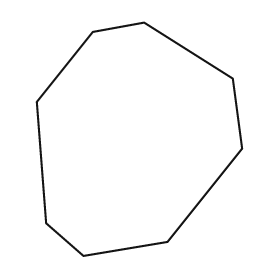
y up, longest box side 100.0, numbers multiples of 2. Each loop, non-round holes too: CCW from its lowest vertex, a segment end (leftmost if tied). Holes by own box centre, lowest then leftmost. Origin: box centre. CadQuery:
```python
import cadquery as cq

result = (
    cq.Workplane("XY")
    .moveTo(-24.0, -50.0)
    .lineTo(12.0, -44.0)
    .lineTo(44.0, -4.0)
    .lineTo(40.0, 26.0)
    .lineTo(2.0, 50.0)
    .lineTo(-20.0, 46.0)
    .lineTo(-44.0, 16.0)
    .lineTo(-40.0, -36.0)
    .close()
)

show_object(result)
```